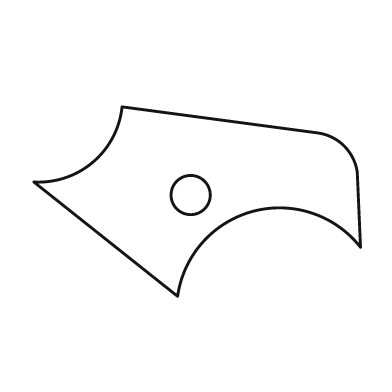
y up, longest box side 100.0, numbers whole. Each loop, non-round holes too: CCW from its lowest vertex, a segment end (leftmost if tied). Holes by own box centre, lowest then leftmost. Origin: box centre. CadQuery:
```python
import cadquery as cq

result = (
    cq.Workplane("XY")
    .moveTo(-6.0, -29.0)
    .threePointArc((17.0, -3.0), (50.0, -14.0))
    .lineTo(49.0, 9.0)
    .threePointArc((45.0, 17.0), (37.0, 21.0))
    .lineTo(-23.0, 29.0)
    .threePointArc((-32.0, 12.0), (-50.0, 6.0))
    .close()
    .moveTo(-2.0, 2.0)
    .circle(6.0)
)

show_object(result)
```